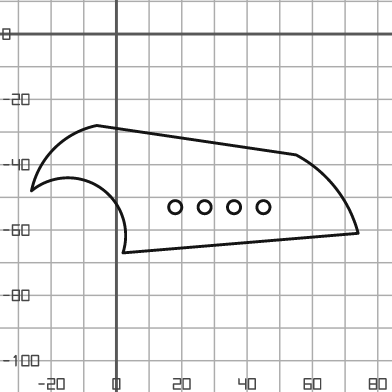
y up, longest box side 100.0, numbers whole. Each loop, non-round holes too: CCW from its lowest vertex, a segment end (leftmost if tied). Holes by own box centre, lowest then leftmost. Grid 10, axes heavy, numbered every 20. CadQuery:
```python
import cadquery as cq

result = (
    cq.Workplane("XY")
    .moveTo(2.0, -67.0)
    .lineTo(74.0, -61.0)
    .threePointArc((67.0, -47.0), (55.0, -37.0))
    .lineTo(-6.0, -28.0)
    .threePointArc((-19.0, -35.0), (-26.0, -48.0))
    .threePointArc((-5.0, -47.0), (2.0, -67.0))
    .close()
    .moveTo(18.0, -53.0)
    .circle(2.0)
    .moveTo(27.0, -53.0)
    .circle(2.0)
    .moveTo(36.0, -53.0)
    .circle(2.0)
    .moveTo(45.0, -53.0)
    .circle(2.0)
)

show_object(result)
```